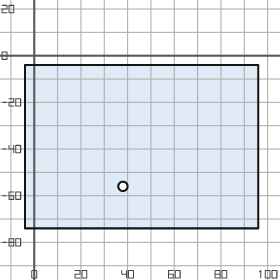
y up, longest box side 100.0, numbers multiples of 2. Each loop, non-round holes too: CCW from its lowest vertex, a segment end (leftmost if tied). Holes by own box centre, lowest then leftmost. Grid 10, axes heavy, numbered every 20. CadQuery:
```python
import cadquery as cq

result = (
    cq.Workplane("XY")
    .moveTo(-4.0, -74.0)
    .lineTo(96.0, -74.0)
    .lineTo(96.0, -4.0)
    .lineTo(-4.0, -4.0)
    .close()
    .moveTo(38.0, -56.0)
    .circle(2.0)
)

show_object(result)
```